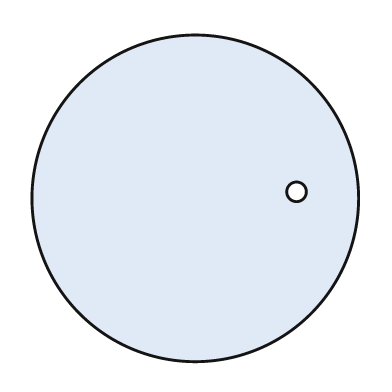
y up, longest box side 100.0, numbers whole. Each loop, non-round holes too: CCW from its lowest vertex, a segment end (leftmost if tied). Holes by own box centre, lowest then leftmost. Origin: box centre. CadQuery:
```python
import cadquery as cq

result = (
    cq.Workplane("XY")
    .moveTo(0.0, 0.0)
    .circle(50.0)
    .moveTo(31.0, 2.0)
    .circle(3.0)
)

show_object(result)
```